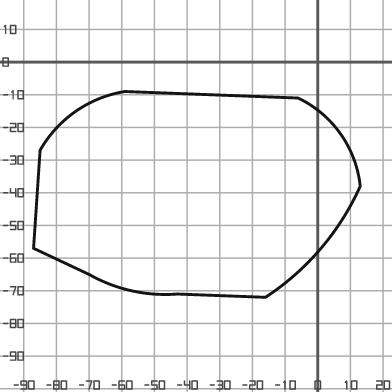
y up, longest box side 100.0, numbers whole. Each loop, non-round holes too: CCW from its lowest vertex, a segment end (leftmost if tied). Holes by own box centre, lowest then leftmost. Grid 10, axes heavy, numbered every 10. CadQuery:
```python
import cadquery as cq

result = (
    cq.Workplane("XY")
    .moveTo(-16.0, -72.0)
    .threePointArc((1.0, -57.0), (13.0, -38.0))
    .threePointArc((7.0, -22.0), (-6.0, -11.0))
    .lineTo(-59.0, -9.0)
    .threePointArc((-74.0, -15.0), (-85.0, -27.0))
    .lineTo(-87.0, -57.0)
    .lineTo(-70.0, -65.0)
    .threePointArc((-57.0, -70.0), (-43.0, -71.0))
    .close()
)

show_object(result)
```